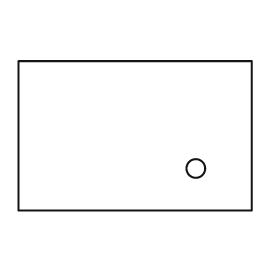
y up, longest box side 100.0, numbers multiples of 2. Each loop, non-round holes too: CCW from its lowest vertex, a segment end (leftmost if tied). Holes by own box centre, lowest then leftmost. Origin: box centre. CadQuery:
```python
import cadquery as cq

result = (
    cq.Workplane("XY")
    .moveTo(-50.0, -32.0)
    .lineTo(50.0, -32.0)
    .lineTo(50.0, 32.0)
    .lineTo(-50.0, 32.0)
    .close()
    .moveTo(26.0, -14.0)
    .circle(4.0)
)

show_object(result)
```